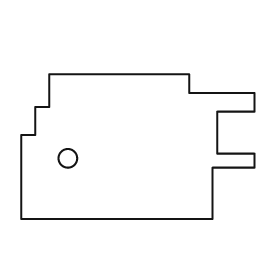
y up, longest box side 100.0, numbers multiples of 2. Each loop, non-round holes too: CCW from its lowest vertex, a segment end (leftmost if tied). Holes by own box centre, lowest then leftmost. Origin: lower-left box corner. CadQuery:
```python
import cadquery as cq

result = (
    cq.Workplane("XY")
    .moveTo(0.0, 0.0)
    .lineTo(82.0, 0.0)
    .lineTo(82.0, 22.0)
    .lineTo(100.0, 22.0)
    .lineTo(100.0, 28.0)
    .lineTo(84.0, 28.0)
    .lineTo(84.0, 46.0)
    .lineTo(100.0, 46.0)
    .lineTo(100.0, 54.0)
    .lineTo(72.0, 54.0)
    .lineTo(72.0, 62.0)
    .lineTo(12.0, 62.0)
    .lineTo(12.0, 48.0)
    .lineTo(6.0, 48.0)
    .lineTo(6.0, 36.0)
    .lineTo(0.0, 36.0)
    .close()
    .moveTo(20.0, 26.0)
    .circle(4.0)
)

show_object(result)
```